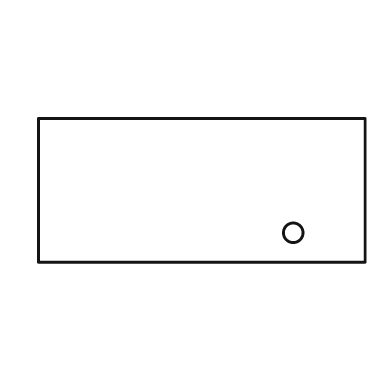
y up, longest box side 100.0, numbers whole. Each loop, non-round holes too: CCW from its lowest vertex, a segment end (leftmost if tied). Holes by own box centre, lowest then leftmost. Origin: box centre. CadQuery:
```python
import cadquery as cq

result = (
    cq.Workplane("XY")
    .moveTo(-50.0, -22.0)
    .lineTo(50.0, -22.0)
    .lineTo(50.0, 22.0)
    .lineTo(-50.0, 22.0)
    .close()
    .moveTo(28.0, -13.0)
    .circle(3.0)
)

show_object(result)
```